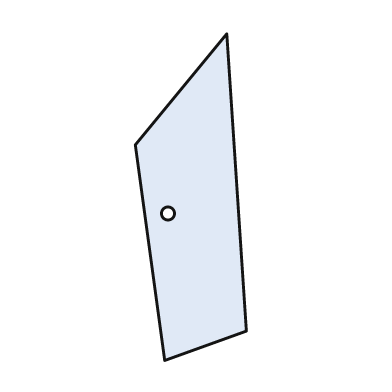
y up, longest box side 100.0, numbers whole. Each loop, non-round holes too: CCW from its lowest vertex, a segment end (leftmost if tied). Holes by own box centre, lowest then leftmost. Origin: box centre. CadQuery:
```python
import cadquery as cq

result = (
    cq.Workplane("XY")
    .moveTo(-8.0, -50.0)
    .lineTo(17.0, -41.0)
    .lineTo(11.0, 50.0)
    .lineTo(-17.0, 16.0)
    .close()
    .moveTo(-7.0, -5.0)
    .circle(2.0)
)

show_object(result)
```